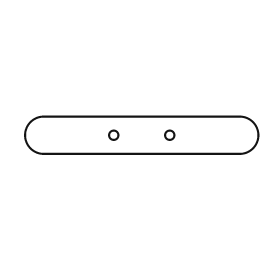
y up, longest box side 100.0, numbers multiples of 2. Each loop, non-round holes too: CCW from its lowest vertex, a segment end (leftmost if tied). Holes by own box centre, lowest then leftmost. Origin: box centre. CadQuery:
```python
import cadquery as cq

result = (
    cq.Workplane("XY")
    .moveTo(-42.0, -8.0)
    .lineTo(42.0, -8.0)
    .threePointArc((50.0, 0.0), (42.0, 8.0))
    .lineTo(-42.0, 8.0)
    .threePointArc((-50.0, 0.0), (-42.0, -8.0))
    .close()
    .moveTo(-12.0, 0.0)
    .circle(2.0)
    .moveTo(12.0, 0.0)
    .circle(2.0)
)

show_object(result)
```